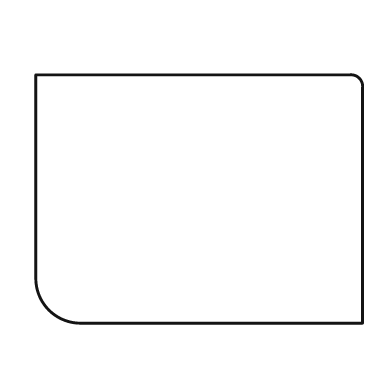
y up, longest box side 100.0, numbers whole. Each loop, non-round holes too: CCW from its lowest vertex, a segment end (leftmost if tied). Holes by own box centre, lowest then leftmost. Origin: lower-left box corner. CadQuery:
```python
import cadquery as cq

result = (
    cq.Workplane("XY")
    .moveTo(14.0, 0.0)
    .lineTo(100.0, 0.0)
    .lineTo(100.0, 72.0)
    .threePointArc((99.0, 75.0), (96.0, 76.0))
    .lineTo(0.0, 76.0)
    .lineTo(0.0, 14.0)
    .threePointArc((4.0, 4.0), (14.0, 0.0))
    .close()
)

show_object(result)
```